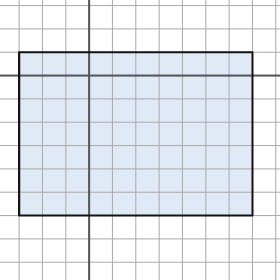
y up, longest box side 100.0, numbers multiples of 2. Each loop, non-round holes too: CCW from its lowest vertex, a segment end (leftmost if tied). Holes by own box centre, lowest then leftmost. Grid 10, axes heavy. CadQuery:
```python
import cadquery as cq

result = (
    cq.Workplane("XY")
    .moveTo(-30.0, -60.0)
    .lineTo(70.0, -60.0)
    .lineTo(70.0, 10.0)
    .lineTo(-30.0, 10.0)
    .close()
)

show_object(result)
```